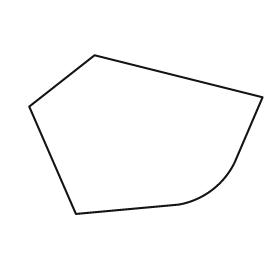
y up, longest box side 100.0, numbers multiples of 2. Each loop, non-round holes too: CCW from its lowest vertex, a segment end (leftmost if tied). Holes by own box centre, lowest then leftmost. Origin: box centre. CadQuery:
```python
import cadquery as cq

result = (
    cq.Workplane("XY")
    .moveTo(-30.0, -34.0)
    .lineTo(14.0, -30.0)
    .threePointArc((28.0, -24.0), (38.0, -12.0))
    .lineTo(50.0, 16.0)
    .lineTo(-22.0, 34.0)
    .lineTo(-50.0, 12.0)
    .close()
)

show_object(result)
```